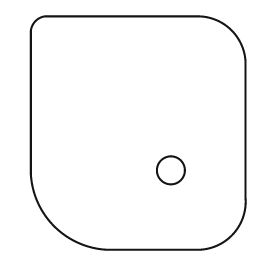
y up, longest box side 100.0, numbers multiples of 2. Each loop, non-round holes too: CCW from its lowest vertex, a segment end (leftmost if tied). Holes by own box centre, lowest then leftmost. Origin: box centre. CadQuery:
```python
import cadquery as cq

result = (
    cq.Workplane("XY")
    .moveTo(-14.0, -50.0)
    .lineTo(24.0, -50.0)
    .threePointArc((40.0, -44.0), (46.0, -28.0))
    .lineTo(46.0, 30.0)
    .threePointArc((40.0, 44.0), (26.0, 50.0))
    .lineTo(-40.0, 50.0)
    .threePointArc((-44.0, 48.0), (-46.0, 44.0))
    .lineTo(-46.0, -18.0)
    .threePointArc((-36.0, -40.0), (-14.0, -50.0))
    .close()
    .moveTo(14.0, -16.0)
    .circle(6.0)
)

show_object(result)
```